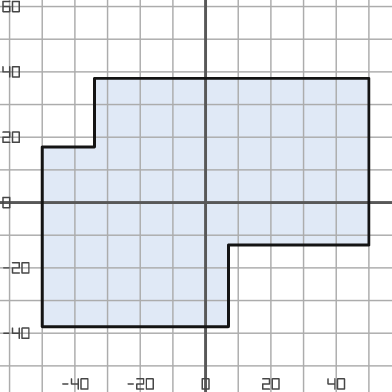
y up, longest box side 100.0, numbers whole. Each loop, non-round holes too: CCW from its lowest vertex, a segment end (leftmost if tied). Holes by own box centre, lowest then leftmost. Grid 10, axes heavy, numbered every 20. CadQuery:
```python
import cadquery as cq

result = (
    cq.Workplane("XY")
    .moveTo(-50.0, -38.0)
    .lineTo(7.0, -38.0)
    .lineTo(7.0, -13.0)
    .lineTo(50.0, -13.0)
    .lineTo(50.0, 38.0)
    .lineTo(-34.0, 38.0)
    .lineTo(-34.0, 17.0)
    .lineTo(-50.0, 17.0)
    .close()
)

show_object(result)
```